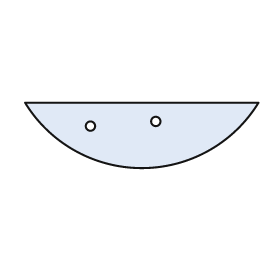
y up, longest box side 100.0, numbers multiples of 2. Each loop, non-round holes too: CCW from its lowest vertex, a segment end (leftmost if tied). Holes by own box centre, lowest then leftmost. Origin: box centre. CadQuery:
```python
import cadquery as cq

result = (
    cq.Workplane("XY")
    .moveTo(-50.0, 14.0)
    .threePointArc((0.0, -14.0), (50.0, 14.0))
    .close()
    .moveTo(-22.0, 4.0)
    .circle(2.0)
    .moveTo(6.0, 6.0)
    .circle(2.0)
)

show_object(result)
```